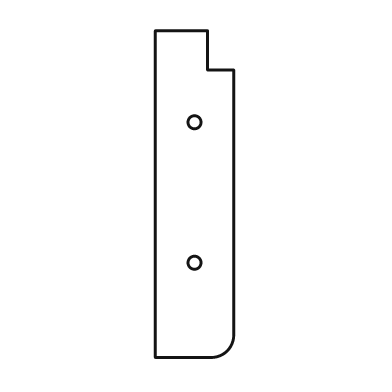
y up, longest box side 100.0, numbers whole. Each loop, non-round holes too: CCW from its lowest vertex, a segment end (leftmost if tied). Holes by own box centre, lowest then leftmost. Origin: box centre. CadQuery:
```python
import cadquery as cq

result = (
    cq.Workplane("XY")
    .moveTo(-12.0, -50.0)
    .lineTo(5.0, -50.0)
    .threePointArc((10.0, -48.0), (12.0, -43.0))
    .lineTo(12.0, 38.0)
    .lineTo(4.0, 38.0)
    .lineTo(4.0, 50.0)
    .lineTo(-12.0, 50.0)
    .close()
    .moveTo(0.0, -21.0)
    .circle(2.0)
    .moveTo(0.0, 22.0)
    .circle(2.0)
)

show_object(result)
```